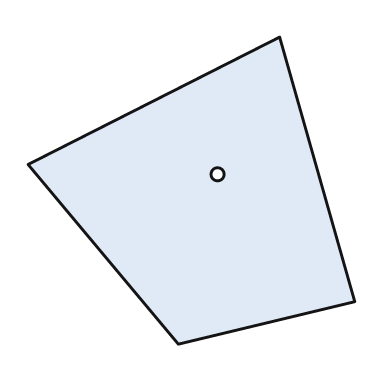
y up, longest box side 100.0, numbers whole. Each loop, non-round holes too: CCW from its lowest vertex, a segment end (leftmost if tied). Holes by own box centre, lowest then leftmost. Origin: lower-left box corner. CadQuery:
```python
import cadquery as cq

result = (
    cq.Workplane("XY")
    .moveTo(46.0, 0.0)
    .lineTo(100.0, 13.0)
    .lineTo(77.0, 94.0)
    .lineTo(0.0, 55.0)
    .close()
    .moveTo(58.0, 52.0)
    .circle(2.0)
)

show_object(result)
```